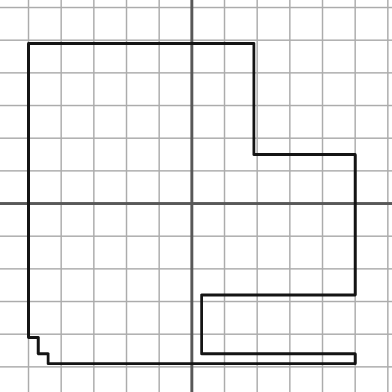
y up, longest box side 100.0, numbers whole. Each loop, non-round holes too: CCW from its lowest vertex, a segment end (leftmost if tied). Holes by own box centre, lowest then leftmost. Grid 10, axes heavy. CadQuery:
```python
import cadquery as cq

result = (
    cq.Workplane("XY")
    .moveTo(-44.0, -49.0)
    .lineTo(50.0, -49.0)
    .lineTo(50.0, -46.0)
    .lineTo(3.0, -46.0)
    .lineTo(3.0, -28.0)
    .lineTo(50.0, -28.0)
    .lineTo(50.0, 15.0)
    .lineTo(19.0, 15.0)
    .lineTo(19.0, 49.0)
    .lineTo(-50.0, 49.0)
    .lineTo(-50.0, -41.0)
    .lineTo(-47.0, -41.0)
    .lineTo(-47.0, -46.0)
    .lineTo(-44.0, -46.0)
    .close()
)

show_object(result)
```